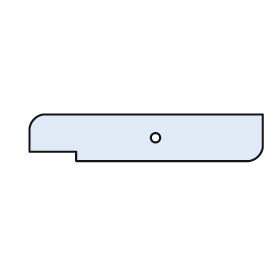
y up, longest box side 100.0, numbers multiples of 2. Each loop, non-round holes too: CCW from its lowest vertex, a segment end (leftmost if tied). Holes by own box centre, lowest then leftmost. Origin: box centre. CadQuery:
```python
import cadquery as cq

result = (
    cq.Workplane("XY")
    .moveTo(-30.0, -10.0)
    .lineTo(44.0, -10.0)
    .threePointArc((48.0, -8.0), (50.0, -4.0))
    .lineTo(50.0, 10.0)
    .lineTo(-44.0, 10.0)
    .threePointArc((-48.0, 8.0), (-50.0, 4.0))
    .lineTo(-50.0, -6.0)
    .lineTo(-30.0, -6.0)
    .close()
    .moveTo(4.0, 0.0)
    .circle(2.0)
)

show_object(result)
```